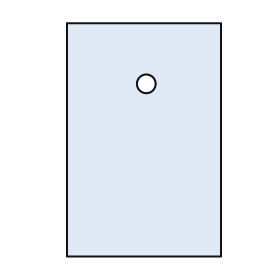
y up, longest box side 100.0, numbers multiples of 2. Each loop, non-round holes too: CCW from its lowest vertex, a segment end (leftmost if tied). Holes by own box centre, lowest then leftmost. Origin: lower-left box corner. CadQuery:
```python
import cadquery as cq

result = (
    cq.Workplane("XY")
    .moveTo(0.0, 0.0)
    .lineTo(66.0, 0.0)
    .lineTo(66.0, 100.0)
    .lineTo(0.0, 100.0)
    .close()
    .moveTo(34.0, 74.0)
    .circle(4.0)
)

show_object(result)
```